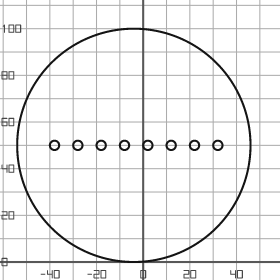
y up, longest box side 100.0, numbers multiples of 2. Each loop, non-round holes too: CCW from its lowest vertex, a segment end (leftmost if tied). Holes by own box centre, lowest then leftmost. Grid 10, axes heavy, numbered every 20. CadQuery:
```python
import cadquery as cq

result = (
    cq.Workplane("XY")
    .moveTo(-4.0, 50.0)
    .circle(50.0)
    .moveTo(-38.0, 50.0)
    .circle(2.0)
    .moveTo(-28.0, 50.0)
    .circle(2.0)
    .moveTo(-18.0, 50.0)
    .circle(2.0)
    .moveTo(-8.0, 50.0)
    .circle(2.0)
    .moveTo(2.0, 50.0)
    .circle(2.0)
    .moveTo(12.0, 50.0)
    .circle(2.0)
    .moveTo(22.0, 50.0)
    .circle(2.0)
    .moveTo(32.0, 50.0)
    .circle(2.0)
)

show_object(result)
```